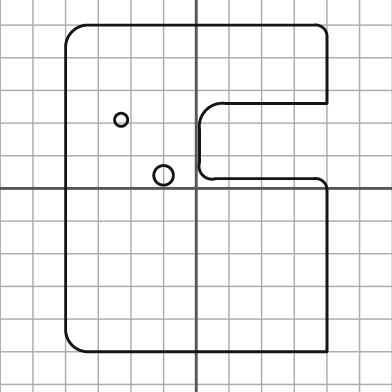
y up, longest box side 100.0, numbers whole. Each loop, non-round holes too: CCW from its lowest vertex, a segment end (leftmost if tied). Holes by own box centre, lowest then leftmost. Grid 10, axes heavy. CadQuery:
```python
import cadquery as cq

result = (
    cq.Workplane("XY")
    .moveTo(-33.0, -50.0)
    .lineTo(40.0, -50.0)
    .lineTo(40.0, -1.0)
    .threePointArc((39.0, 2.0), (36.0, 3.0))
    .lineTo(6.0, 3.0)
    .threePointArc((2.0, 4.0), (1.0, 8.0))
    .lineTo(1.0, 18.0)
    .threePointArc((3.0, 24.0), (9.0, 26.0))
    .lineTo(40.0, 26.0)
    .lineTo(40.0, 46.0)
    .threePointArc((39.0, 49.0), (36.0, 50.0))
    .lineTo(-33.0, 50.0)
    .threePointArc((-38.0, 48.0), (-40.0, 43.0))
    .lineTo(-40.0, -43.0)
    .threePointArc((-38.0, -48.0), (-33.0, -50.0))
    .close()
    .moveTo(-10.0, 4.0)
    .circle(3.0)
    .moveTo(-23.0, 21.0)
    .circle(2.0)
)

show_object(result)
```